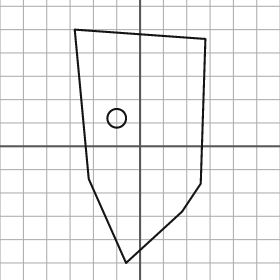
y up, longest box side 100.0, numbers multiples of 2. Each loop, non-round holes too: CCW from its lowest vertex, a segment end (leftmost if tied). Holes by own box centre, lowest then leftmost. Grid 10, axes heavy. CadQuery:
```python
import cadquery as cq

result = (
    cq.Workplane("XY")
    .moveTo(-6.0, -50.0)
    .lineTo(18.0, -28.0)
    .lineTo(26.0, -16.0)
    .lineTo(28.0, 46.0)
    .lineTo(-28.0, 50.0)
    .lineTo(-22.0, -14.0)
    .close()
    .moveTo(-10.0, 12.0)
    .circle(4.0)
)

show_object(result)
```